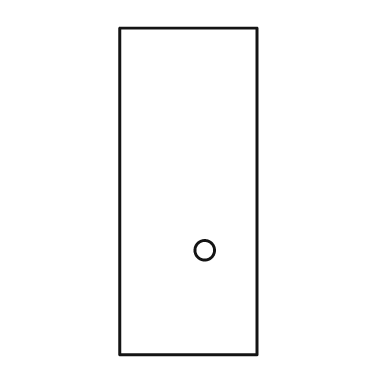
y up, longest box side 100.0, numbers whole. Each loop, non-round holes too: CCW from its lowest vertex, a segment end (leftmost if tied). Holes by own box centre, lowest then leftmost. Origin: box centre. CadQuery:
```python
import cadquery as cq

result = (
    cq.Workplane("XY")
    .moveTo(-21.0, -50.0)
    .lineTo(21.0, -50.0)
    .lineTo(21.0, 50.0)
    .lineTo(-21.0, 50.0)
    .close()
    .moveTo(5.0, -18.0)
    .circle(3.0)
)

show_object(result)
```